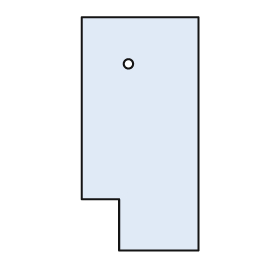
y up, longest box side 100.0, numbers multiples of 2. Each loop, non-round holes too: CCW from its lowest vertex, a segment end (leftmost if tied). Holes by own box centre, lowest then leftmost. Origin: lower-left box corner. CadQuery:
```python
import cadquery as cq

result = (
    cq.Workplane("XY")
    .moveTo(16.0, 0.0)
    .lineTo(50.0, 0.0)
    .lineTo(50.0, 100.0)
    .lineTo(0.0, 100.0)
    .lineTo(0.0, 22.0)
    .lineTo(16.0, 22.0)
    .close()
    .moveTo(20.0, 80.0)
    .circle(2.0)
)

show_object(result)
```